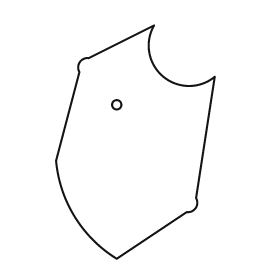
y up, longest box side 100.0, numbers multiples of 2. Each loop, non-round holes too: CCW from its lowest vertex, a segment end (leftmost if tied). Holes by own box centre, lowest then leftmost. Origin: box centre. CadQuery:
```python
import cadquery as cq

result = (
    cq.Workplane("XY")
    .moveTo(-8.0, -50.0)
    .lineTo(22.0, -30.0)
    .threePointArc((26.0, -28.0), (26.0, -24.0))
    .lineTo(34.0, 28.0)
    .threePointArc((12.0, 28.0), (8.0, 50.0))
    .lineTo(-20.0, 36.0)
    .threePointArc((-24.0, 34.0), (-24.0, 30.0))
    .lineTo(-34.0, -8.0)
    .threePointArc((-26.0, -32.0), (-8.0, -50.0))
    .close()
    .moveTo(-8.0, 16.0)
    .circle(2.0)
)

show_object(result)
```